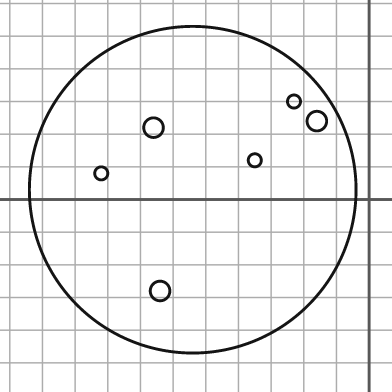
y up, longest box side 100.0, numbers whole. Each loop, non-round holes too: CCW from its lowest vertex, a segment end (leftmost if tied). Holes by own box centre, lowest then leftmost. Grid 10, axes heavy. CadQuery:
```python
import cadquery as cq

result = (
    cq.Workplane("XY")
    .moveTo(-54.0, 3.0)
    .circle(50.0)
    .moveTo(-64.0, -28.0)
    .circle(3.0)
    .moveTo(-82.0, 8.0)
    .circle(2.0)
    .moveTo(-35.0, 12.0)
    .circle(2.0)
    .moveTo(-66.0, 22.0)
    .circle(3.0)
    .moveTo(-16.0, 24.0)
    .circle(3.0)
    .moveTo(-23.0, 30.0)
    .circle(2.0)
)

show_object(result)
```